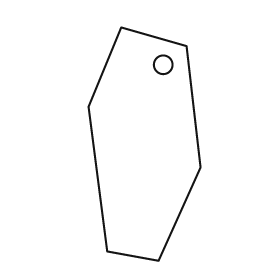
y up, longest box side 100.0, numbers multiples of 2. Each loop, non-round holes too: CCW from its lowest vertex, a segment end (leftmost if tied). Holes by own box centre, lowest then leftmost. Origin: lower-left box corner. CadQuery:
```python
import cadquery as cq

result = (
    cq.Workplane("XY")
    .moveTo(30.0, 0.0)
    .lineTo(48.0, 40.0)
    .lineTo(42.0, 92.0)
    .lineTo(14.0, 100.0)
    .lineTo(0.0, 66.0)
    .lineTo(8.0, 4.0)
    .close()
    .moveTo(32.0, 84.0)
    .circle(4.0)
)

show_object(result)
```